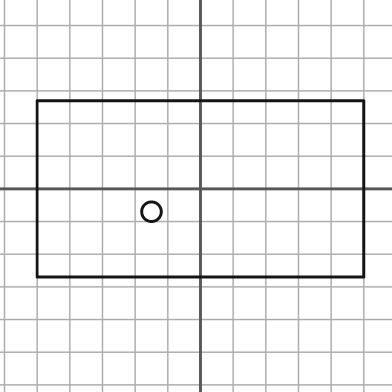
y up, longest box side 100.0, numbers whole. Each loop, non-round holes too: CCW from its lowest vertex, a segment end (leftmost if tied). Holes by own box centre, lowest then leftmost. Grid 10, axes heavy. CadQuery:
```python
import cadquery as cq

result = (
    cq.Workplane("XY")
    .moveTo(-50.0, -27.0)
    .lineTo(50.0, -27.0)
    .lineTo(50.0, 27.0)
    .lineTo(-50.0, 27.0)
    .close()
    .moveTo(-15.0, -7.0)
    .circle(3.0)
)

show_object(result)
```